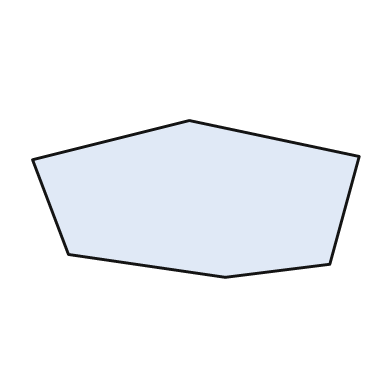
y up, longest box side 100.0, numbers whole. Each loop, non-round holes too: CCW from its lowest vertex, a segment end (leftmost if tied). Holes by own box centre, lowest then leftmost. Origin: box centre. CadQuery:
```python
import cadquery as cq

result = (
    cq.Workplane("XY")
    .moveTo(9.0, -24.0)
    .lineTo(41.0, -20.0)
    .lineTo(50.0, 13.0)
    .lineTo(-2.0, 24.0)
    .lineTo(-50.0, 12.0)
    .lineTo(-39.0, -17.0)
    .close()
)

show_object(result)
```